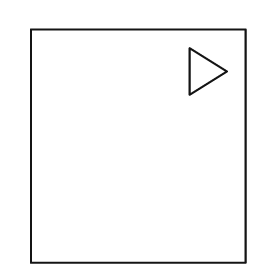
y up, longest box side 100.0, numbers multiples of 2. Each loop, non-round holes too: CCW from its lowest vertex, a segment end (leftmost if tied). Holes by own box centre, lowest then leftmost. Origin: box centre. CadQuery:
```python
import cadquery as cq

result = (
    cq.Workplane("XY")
    .moveTo(-46.0, -50.0)
    .lineTo(46.0, -50.0)
    .lineTo(46.0, 50.0)
    .lineTo(-46.0, 50.0)
    .close()
    .moveTo(22.0, 22.0)
    .lineTo(38.0, 32.0)
    .lineTo(22.0, 42.0)
    .close()
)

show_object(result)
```